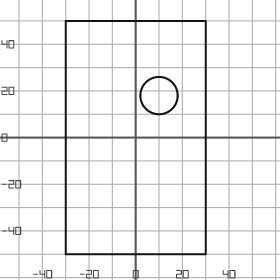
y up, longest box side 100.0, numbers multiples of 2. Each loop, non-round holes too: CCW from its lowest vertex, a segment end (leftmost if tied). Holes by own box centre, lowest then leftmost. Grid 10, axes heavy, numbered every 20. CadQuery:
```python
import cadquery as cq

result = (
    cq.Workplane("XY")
    .moveTo(-30.0, -50.0)
    .lineTo(30.0, -50.0)
    .lineTo(30.0, 50.0)
    .lineTo(-30.0, 50.0)
    .close()
    .moveTo(10.0, 18.0)
    .circle(8.0)
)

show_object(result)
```